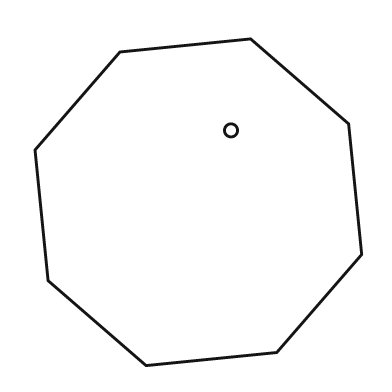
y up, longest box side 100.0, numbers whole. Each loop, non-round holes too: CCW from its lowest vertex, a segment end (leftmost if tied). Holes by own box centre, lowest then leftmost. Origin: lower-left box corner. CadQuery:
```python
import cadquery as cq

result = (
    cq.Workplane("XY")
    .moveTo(34.0, 0.0)
    .lineTo(74.0, 4.0)
    .lineTo(100.0, 34.0)
    .lineTo(96.0, 74.0)
    .lineTo(66.0, 100.0)
    .lineTo(26.0, 96.0)
    .lineTo(0.0, 66.0)
    .lineTo(4.0, 26.0)
    .close()
    .moveTo(60.0, 72.0)
    .circle(2.0)
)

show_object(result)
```